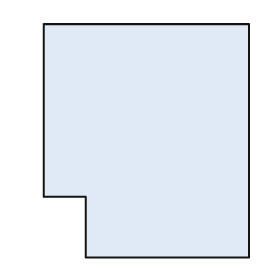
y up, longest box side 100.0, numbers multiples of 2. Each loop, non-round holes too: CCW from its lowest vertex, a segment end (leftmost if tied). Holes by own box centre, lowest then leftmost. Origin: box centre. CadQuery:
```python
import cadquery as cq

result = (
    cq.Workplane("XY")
    .moveTo(-26.0, -50.0)
    .lineTo(44.0, -50.0)
    .lineTo(44.0, 50.0)
    .lineTo(-44.0, 50.0)
    .lineTo(-44.0, -24.0)
    .lineTo(-26.0, -24.0)
    .close()
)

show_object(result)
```